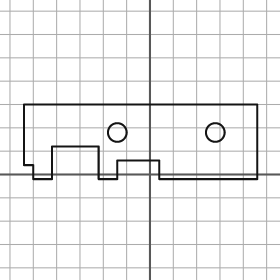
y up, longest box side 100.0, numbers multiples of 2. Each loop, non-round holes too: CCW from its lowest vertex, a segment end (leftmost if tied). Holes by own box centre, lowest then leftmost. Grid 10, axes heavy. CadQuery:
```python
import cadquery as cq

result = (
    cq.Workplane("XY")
    .moveTo(-50.0, -2.0)
    .lineTo(-42.0, -2.0)
    .lineTo(-42.0, 12.0)
    .lineTo(-22.0, 12.0)
    .lineTo(-22.0, -2.0)
    .lineTo(-14.0, -2.0)
    .lineTo(-14.0, 6.0)
    .lineTo(4.0, 6.0)
    .lineTo(4.0, -2.0)
    .lineTo(46.0, -2.0)
    .lineTo(46.0, 30.0)
    .lineTo(-54.0, 30.0)
    .lineTo(-54.0, 4.0)
    .lineTo(-50.0, 4.0)
    .close()
    .moveTo(-14.0, 18.0)
    .circle(4.0)
    .moveTo(28.0, 18.0)
    .circle(4.0)
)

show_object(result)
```